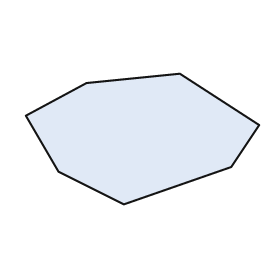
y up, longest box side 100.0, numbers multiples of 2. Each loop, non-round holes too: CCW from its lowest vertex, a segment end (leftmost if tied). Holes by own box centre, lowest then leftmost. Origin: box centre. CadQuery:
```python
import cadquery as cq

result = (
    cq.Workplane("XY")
    .moveTo(-8.0, -28.0)
    .lineTo(38.0, -12.0)
    .lineTo(50.0, 6.0)
    .lineTo(16.0, 28.0)
    .lineTo(-24.0, 24.0)
    .lineTo(-50.0, 10.0)
    .lineTo(-36.0, -14.0)
    .close()
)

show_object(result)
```